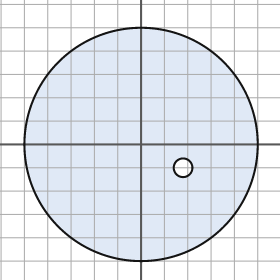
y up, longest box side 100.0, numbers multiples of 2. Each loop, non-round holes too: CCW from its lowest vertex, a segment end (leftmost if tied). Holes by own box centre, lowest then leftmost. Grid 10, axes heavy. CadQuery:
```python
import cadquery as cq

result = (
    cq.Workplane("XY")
    .moveTo(0.0, 0.0)
    .circle(50.0)
    .moveTo(18.0, -10.0)
    .circle(4.0)
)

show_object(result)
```